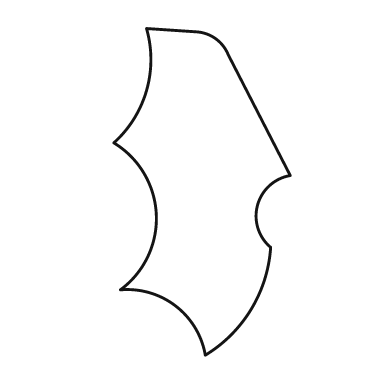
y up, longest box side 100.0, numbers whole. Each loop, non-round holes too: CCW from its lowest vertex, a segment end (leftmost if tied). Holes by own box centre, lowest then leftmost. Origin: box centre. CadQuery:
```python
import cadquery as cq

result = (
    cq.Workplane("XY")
    .moveTo(1.0, -50.0)
    .threePointArc((15.0, -36.0), (21.0, -17.0))
    .threePointArc((17.0, -4.0), (27.0, 5.0))
    .lineTo(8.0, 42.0)
    .threePointArc((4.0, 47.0), (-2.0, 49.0))
    .lineTo(-17.0, 50.0)
    .threePointArc((-17.0, 31.0), (-27.0, 15.0))
    .threePointArc((-14.0, -7.0), (-25.0, -30.0))
    .threePointArc((-8.0, -35.0), (1.0, -50.0))
    .close()
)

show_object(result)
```